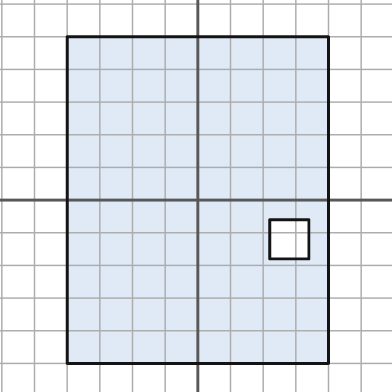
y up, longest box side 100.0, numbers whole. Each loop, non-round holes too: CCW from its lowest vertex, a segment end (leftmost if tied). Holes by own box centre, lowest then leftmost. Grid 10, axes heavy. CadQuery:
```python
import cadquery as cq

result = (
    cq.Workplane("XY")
    .moveTo(-40.0, -50.0)
    .lineTo(40.0, -50.0)
    .lineTo(40.0, 50.0)
    .lineTo(-40.0, 50.0)
    .close()
    .moveTo(22.0, -18.0)
    .lineTo(34.0, -18.0)
    .lineTo(34.0, -6.0)
    .lineTo(22.0, -6.0)
    .close()
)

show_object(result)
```